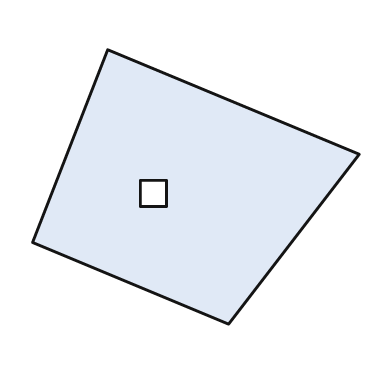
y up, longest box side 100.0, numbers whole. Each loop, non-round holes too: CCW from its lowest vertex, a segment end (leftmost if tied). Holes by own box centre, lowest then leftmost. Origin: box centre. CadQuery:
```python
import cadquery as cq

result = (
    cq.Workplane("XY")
    .moveTo(10.0, -42.0)
    .lineTo(50.0, 10.0)
    .lineTo(-27.0, 42.0)
    .lineTo(-50.0, -17.0)
    .close()
    .moveTo(-17.0, -6.0)
    .lineTo(-9.0, -6.0)
    .lineTo(-9.0, 2.0)
    .lineTo(-17.0, 2.0)
    .close()
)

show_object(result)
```